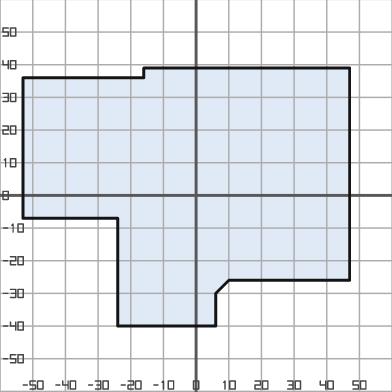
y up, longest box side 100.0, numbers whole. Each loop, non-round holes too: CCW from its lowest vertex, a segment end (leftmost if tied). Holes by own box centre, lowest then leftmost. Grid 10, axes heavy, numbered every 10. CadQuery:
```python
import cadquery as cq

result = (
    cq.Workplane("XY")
    .moveTo(-24.0, -40.0)
    .lineTo(6.0, -40.0)
    .lineTo(6.0, -30.0)
    .lineTo(10.0, -26.0)
    .lineTo(47.0, -26.0)
    .lineTo(47.0, 39.0)
    .lineTo(-16.0, 39.0)
    .lineTo(-16.0, 36.0)
    .lineTo(-53.0, 36.0)
    .lineTo(-53.0, -7.0)
    .lineTo(-24.0, -7.0)
    .close()
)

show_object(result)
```